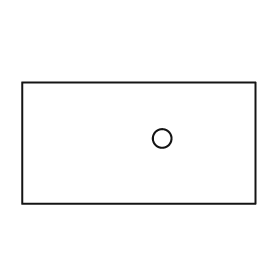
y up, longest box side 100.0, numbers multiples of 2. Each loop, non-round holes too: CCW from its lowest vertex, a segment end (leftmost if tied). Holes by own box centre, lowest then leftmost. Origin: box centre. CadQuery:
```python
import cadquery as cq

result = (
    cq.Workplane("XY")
    .moveTo(-50.0, -26.0)
    .lineTo(50.0, -26.0)
    .lineTo(50.0, 26.0)
    .lineTo(-50.0, 26.0)
    .close()
    .moveTo(10.0, 2.0)
    .circle(4.0)
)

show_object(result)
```